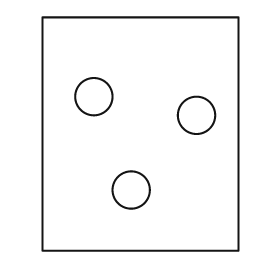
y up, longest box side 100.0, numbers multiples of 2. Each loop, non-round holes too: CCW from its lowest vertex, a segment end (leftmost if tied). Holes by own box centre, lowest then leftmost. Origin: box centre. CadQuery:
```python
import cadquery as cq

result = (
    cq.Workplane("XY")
    .moveTo(-42.0, -50.0)
    .lineTo(42.0, -50.0)
    .lineTo(42.0, 50.0)
    .lineTo(-42.0, 50.0)
    .close()
    .moveTo(-4.0, -24.0)
    .circle(8.0)
    .moveTo(24.0, 8.0)
    .circle(8.0)
    .moveTo(-20.0, 16.0)
    .circle(8.0)
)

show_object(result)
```